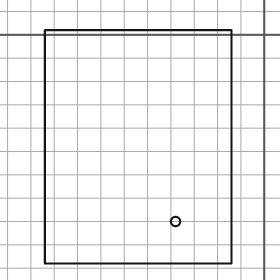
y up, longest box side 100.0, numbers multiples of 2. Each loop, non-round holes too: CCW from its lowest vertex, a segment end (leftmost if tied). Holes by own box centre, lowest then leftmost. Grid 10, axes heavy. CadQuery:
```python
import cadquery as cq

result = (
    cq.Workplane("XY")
    .moveTo(-94.0, -98.0)
    .lineTo(-14.0, -98.0)
    .lineTo(-14.0, 2.0)
    .lineTo(-94.0, 2.0)
    .close()
    .moveTo(-38.0, -80.0)
    .circle(2.0)
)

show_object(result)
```